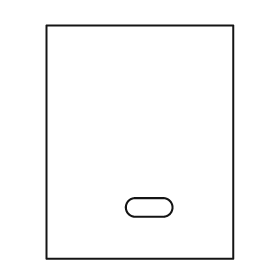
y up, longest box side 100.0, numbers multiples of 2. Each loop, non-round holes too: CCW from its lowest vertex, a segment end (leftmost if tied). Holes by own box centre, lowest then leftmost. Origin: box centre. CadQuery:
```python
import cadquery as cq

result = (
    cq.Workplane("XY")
    .moveTo(-40.0, -50.0)
    .lineTo(40.0, -50.0)
    .lineTo(40.0, 50.0)
    .lineTo(-40.0, 50.0)
    .close()
    .moveTo(-2.0, -32.0)
    .lineTo(10.0, -32.0)
    .threePointArc((14.0, -28.0), (10.0, -24.0))
    .lineTo(-2.0, -24.0)
    .threePointArc((-6.0, -28.0), (-2.0, -32.0))
    .close()
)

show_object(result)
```